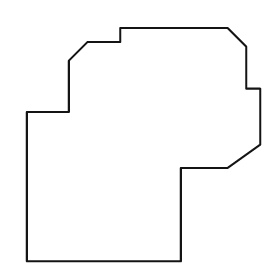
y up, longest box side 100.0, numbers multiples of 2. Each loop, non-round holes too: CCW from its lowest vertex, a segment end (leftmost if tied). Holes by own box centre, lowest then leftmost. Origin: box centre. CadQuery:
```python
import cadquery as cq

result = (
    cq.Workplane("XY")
    .moveTo(-50.0, -50.0)
    .lineTo(16.0, -50.0)
    .lineTo(16.0, -10.0)
    .lineTo(36.0, -10.0)
    .lineTo(50.0, 0.0)
    .lineTo(50.0, 24.0)
    .lineTo(44.0, 24.0)
    .lineTo(44.0, 42.0)
    .lineTo(36.0, 50.0)
    .lineTo(-10.0, 50.0)
    .lineTo(-10.0, 44.0)
    .lineTo(-24.0, 44.0)
    .lineTo(-32.0, 36.0)
    .lineTo(-32.0, 14.0)
    .lineTo(-50.0, 14.0)
    .close()
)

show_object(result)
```